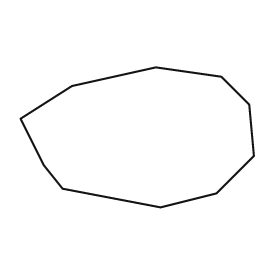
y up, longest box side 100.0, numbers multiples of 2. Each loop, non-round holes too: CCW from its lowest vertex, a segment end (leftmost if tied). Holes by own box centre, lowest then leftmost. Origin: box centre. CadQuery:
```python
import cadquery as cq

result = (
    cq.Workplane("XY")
    .moveTo(10.0, -30.0)
    .lineTo(34.0, -24.0)
    .lineTo(50.0, -8.0)
    .lineTo(48.0, 14.0)
    .lineTo(36.0, 26.0)
    .lineTo(8.0, 30.0)
    .lineTo(-28.0, 22.0)
    .lineTo(-50.0, 8.0)
    .lineTo(-40.0, -12.0)
    .lineTo(-32.0, -22.0)
    .close()
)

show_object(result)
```